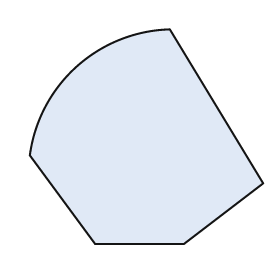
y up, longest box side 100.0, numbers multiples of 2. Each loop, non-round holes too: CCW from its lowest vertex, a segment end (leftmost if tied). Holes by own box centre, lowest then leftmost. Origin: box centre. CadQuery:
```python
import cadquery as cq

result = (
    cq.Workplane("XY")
    .moveTo(-22.0, -46.0)
    .lineTo(16.0, -46.0)
    .lineTo(50.0, -20.0)
    .lineTo(10.0, 46.0)
    .threePointArc((-30.0, 30.0), (-50.0, -8.0))
    .close()
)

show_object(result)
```